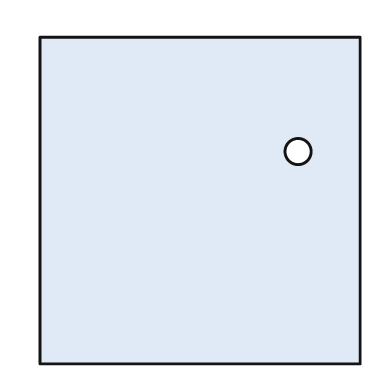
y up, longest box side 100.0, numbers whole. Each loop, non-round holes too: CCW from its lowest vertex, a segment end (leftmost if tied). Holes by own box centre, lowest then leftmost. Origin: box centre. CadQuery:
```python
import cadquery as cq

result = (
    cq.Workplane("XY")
    .moveTo(-49.0, -50.0)
    .lineTo(49.0, -50.0)
    .lineTo(49.0, 50.0)
    .lineTo(-49.0, 50.0)
    .close()
    .moveTo(30.0, 15.0)
    .circle(4.0)
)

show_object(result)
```